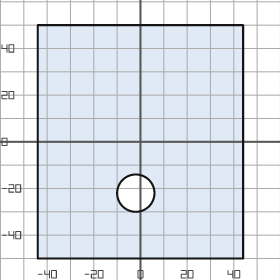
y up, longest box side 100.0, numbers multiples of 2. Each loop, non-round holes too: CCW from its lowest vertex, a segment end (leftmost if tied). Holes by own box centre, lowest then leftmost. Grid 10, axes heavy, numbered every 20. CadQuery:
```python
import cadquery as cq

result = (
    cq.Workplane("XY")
    .moveTo(-44.0, -50.0)
    .lineTo(44.0, -50.0)
    .lineTo(44.0, 50.0)
    .lineTo(-44.0, 50.0)
    .close()
    .moveTo(-2.0, -22.0)
    .circle(8.0)
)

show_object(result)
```